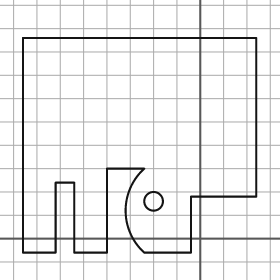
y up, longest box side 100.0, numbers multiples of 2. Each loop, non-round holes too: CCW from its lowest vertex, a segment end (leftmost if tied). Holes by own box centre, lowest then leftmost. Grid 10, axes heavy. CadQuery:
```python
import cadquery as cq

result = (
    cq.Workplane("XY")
    .moveTo(-76.0, -6.0)
    .lineTo(-62.0, -6.0)
    .lineTo(-62.0, 24.0)
    .lineTo(-54.0, 24.0)
    .lineTo(-54.0, -6.0)
    .lineTo(-40.0, -6.0)
    .lineTo(-40.0, 30.0)
    .lineTo(-24.0, 30.0)
    .threePointArc((-32.0, 12.0), (-24.0, -6.0))
    .lineTo(-4.0, -6.0)
    .lineTo(-4.0, 18.0)
    .lineTo(24.0, 18.0)
    .lineTo(24.0, 86.0)
    .lineTo(-76.0, 86.0)
    .close()
    .moveTo(-20.0, 16.0)
    .circle(4.0)
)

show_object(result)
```